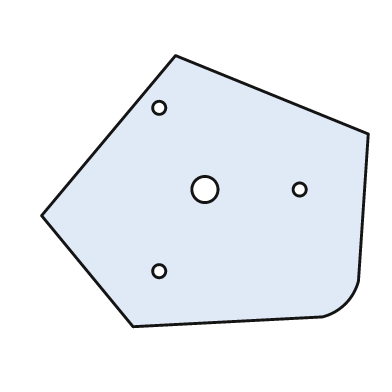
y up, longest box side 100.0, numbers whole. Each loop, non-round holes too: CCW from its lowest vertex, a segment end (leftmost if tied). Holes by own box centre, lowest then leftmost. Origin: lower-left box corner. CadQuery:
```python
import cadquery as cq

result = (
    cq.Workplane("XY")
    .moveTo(28.0, 0.0)
    .lineTo(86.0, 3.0)
    .threePointArc((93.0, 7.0), (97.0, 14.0))
    .lineTo(100.0, 59.0)
    .lineTo(41.0, 83.0)
    .lineTo(0.0, 34.0)
    .close()
    .moveTo(36.0, 17.0)
    .circle(2.0)
    .moveTo(50.0, 42.0)
    .circle(4.0)
    .moveTo(79.0, 42.0)
    .circle(2.0)
    .moveTo(36.0, 67.0)
    .circle(2.0)
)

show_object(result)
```